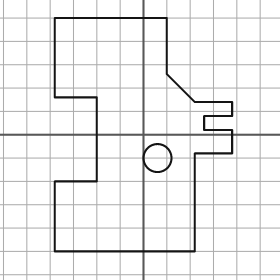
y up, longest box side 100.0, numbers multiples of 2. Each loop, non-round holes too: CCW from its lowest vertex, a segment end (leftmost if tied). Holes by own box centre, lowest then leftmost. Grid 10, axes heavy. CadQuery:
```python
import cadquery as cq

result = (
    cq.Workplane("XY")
    .moveTo(-38.0, -50.0)
    .lineTo(22.0, -50.0)
    .lineTo(22.0, -8.0)
    .lineTo(38.0, -8.0)
    .lineTo(38.0, 2.0)
    .lineTo(26.0, 2.0)
    .lineTo(26.0, 8.0)
    .lineTo(38.0, 8.0)
    .lineTo(38.0, 14.0)
    .lineTo(22.0, 14.0)
    .lineTo(10.0, 26.0)
    .lineTo(10.0, 50.0)
    .lineTo(-38.0, 50.0)
    .lineTo(-38.0, 16.0)
    .lineTo(-20.0, 16.0)
    .lineTo(-20.0, -20.0)
    .lineTo(-38.0, -20.0)
    .close()
    .moveTo(6.0, -10.0)
    .circle(6.0)
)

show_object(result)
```